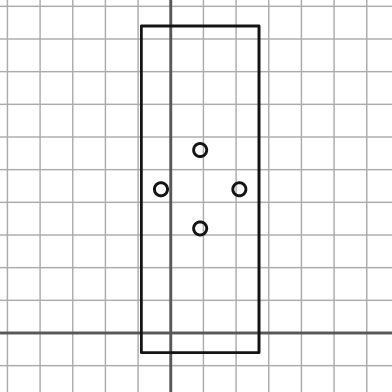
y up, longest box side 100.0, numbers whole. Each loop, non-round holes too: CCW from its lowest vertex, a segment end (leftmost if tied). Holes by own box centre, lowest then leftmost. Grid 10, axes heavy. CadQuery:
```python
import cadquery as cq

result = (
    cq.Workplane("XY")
    .moveTo(-9.0, -6.0)
    .lineTo(27.0, -6.0)
    .lineTo(27.0, 94.0)
    .lineTo(-9.0, 94.0)
    .close()
    .moveTo(9.0, 32.0)
    .circle(2.0)
    .moveTo(-3.0, 44.0)
    .circle(2.0)
    .moveTo(21.0, 44.0)
    .circle(2.0)
    .moveTo(9.0, 56.0)
    .circle(2.0)
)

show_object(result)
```